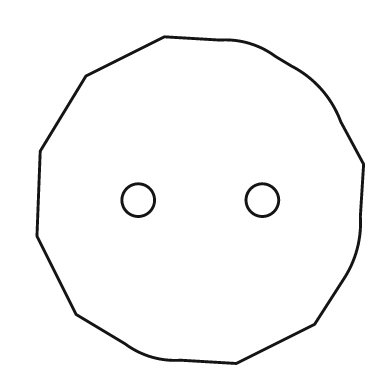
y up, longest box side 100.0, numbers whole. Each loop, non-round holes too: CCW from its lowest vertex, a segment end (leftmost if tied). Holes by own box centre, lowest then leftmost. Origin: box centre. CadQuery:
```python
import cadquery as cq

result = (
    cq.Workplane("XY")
    .moveTo(11.0, -50.0)
    .lineTo(35.0, -38.0)
    .lineTo(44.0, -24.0)
    .threePointArc((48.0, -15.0), (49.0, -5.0))
    .lineTo(50.0, 11.0)
    .lineTo(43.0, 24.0)
    .threePointArc((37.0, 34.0), (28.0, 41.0))
    .lineTo(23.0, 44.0)
    .threePointArc((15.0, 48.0), (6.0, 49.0))
    .lineTo(-11.0, 50.0)
    .lineTo(-35.0, 38.0)
    .lineTo(-49.0, 15.0)
    .lineTo(-50.0, -11.0)
    .lineTo(-38.0, -35.0)
    .lineTo(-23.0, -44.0)
    .threePointArc((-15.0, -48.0), (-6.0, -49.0))
    .close()
    .moveTo(-19.0, 0.0)
    .circle(5.0)
    .moveTo(19.0, 0.0)
    .circle(5.0)
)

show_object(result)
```